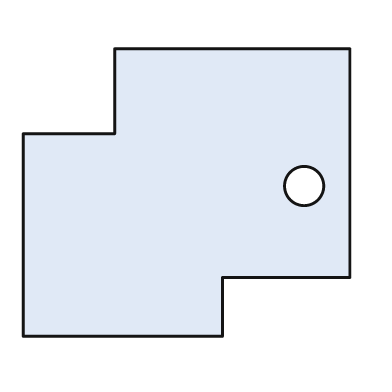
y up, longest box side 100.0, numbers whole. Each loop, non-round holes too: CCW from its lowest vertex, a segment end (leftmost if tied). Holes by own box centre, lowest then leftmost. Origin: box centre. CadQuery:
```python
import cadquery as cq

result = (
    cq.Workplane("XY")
    .moveTo(-50.0, -44.0)
    .lineTo(11.0, -44.0)
    .lineTo(11.0, -26.0)
    .lineTo(50.0, -26.0)
    .lineTo(50.0, 44.0)
    .lineTo(-22.0, 44.0)
    .lineTo(-22.0, 18.0)
    .lineTo(-50.0, 18.0)
    .close()
    .moveTo(36.0, 2.0)
    .circle(6.0)
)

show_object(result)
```